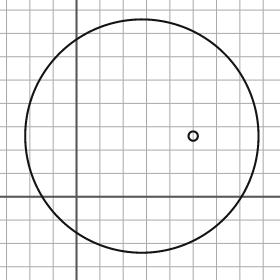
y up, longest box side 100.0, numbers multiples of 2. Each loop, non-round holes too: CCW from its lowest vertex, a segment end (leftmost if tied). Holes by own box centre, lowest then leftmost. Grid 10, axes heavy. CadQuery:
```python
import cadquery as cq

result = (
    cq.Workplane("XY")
    .moveTo(28.0, 26.0)
    .circle(50.0)
    .moveTo(50.0, 26.0)
    .circle(2.0)
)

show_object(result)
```